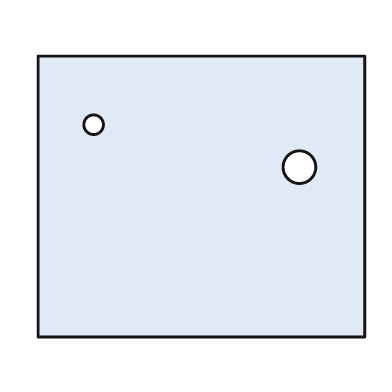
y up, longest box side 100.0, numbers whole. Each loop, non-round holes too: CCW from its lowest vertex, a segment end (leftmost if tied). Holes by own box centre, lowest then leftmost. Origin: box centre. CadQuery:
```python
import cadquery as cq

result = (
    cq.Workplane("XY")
    .moveTo(-50.0, -43.0)
    .lineTo(50.0, -43.0)
    .lineTo(50.0, 43.0)
    .lineTo(-50.0, 43.0)
    .close()
    .moveTo(30.0, 9.0)
    .circle(5.0)
    .moveTo(-33.0, 22.0)
    .circle(3.0)
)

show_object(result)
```